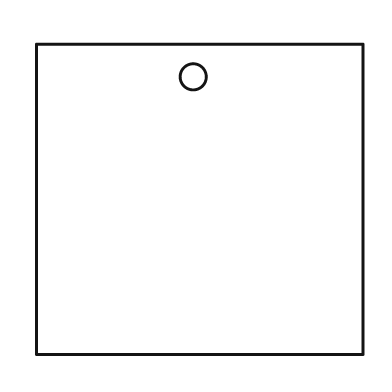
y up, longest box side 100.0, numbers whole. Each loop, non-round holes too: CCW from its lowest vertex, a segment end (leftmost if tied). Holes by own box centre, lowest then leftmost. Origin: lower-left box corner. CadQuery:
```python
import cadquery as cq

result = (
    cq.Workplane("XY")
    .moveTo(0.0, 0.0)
    .lineTo(100.0, 0.0)
    .lineTo(100.0, 95.0)
    .lineTo(0.0, 95.0)
    .close()
    .moveTo(48.0, 85.0)
    .circle(4.0)
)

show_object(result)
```